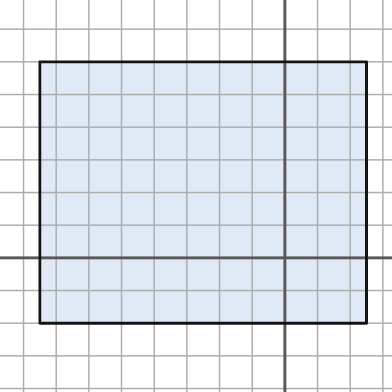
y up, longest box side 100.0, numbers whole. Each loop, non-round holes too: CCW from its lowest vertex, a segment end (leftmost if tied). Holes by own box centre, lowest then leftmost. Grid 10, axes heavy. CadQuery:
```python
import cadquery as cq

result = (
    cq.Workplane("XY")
    .moveTo(-75.0, -20.0)
    .lineTo(25.0, -20.0)
    .lineTo(25.0, 60.0)
    .lineTo(-75.0, 60.0)
    .close()
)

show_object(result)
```